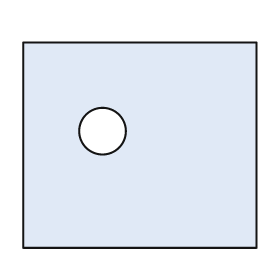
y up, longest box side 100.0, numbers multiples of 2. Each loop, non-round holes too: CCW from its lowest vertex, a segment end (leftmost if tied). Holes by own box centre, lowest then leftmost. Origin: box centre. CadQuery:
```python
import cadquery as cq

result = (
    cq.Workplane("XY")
    .moveTo(-50.0, -44.0)
    .lineTo(50.0, -44.0)
    .lineTo(50.0, 44.0)
    .lineTo(-50.0, 44.0)
    .close()
    .moveTo(-16.0, 6.0)
    .circle(10.0)
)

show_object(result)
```